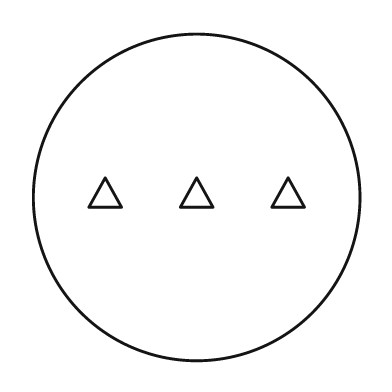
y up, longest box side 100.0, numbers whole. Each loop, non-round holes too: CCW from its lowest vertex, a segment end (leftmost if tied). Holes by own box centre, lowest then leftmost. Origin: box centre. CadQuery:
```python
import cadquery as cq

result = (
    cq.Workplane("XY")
    .moveTo(0.0, 0.0)
    .circle(50.0)
    .moveTo(-33.0, -3.0)
    .lineTo(-23.0, -3.0)
    .lineTo(-28.0, 6.0)
    .close()
    .moveTo(-5.0, -3.0)
    .lineTo(5.0, -3.0)
    .lineTo(0.0, 6.0)
    .close()
    .moveTo(23.0, -3.0)
    .lineTo(33.0, -3.0)
    .lineTo(28.0, 6.0)
    .close()
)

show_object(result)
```